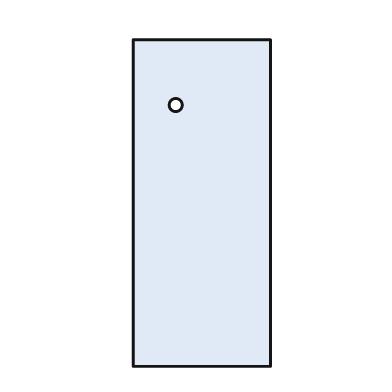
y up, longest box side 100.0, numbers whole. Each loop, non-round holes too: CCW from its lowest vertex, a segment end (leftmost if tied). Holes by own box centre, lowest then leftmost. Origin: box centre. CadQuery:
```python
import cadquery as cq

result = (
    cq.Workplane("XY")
    .moveTo(-21.0, -50.0)
    .lineTo(21.0, -50.0)
    .lineTo(21.0, 50.0)
    .lineTo(-21.0, 50.0)
    .close()
    .moveTo(-8.0, 30.0)
    .circle(2.0)
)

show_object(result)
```